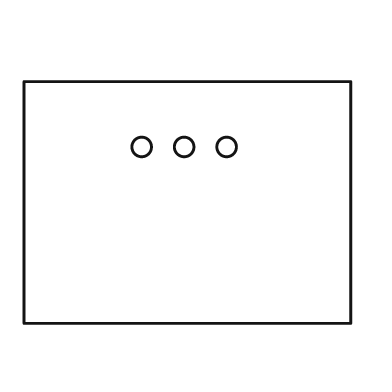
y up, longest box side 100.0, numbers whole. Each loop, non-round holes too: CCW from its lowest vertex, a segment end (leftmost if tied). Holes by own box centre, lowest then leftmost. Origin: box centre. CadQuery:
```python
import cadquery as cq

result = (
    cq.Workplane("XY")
    .moveTo(-50.0, -37.0)
    .lineTo(50.0, -37.0)
    .lineTo(50.0, 37.0)
    .lineTo(-50.0, 37.0)
    .close()
    .moveTo(-14.0, 17.0)
    .circle(3.0)
    .moveTo(-1.0, 17.0)
    .circle(3.0)
    .moveTo(12.0, 17.0)
    .circle(3.0)
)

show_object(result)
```